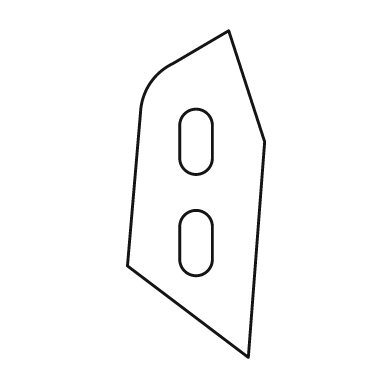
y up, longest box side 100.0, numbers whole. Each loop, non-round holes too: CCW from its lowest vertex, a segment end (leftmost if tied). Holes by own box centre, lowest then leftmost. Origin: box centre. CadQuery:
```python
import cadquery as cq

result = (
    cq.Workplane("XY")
    .moveTo(16.0, -50.0)
    .lineTo(21.0, 16.0)
    .lineTo(10.0, 50.0)
    .lineTo(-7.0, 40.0)
    .threePointArc((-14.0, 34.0), (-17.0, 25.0))
    .lineTo(-21.0, -22.0)
    .close()
    .moveTo(-5.0, -20.0)
    .threePointArc((0.0, -25.0), (5.0, -20.0))
    .lineTo(5.0, -10.0)
    .threePointArc((0.0, -5.0), (-5.0, -10.0))
    .close()
    .moveTo(-5.0, 11.0)
    .threePointArc((0.0, 6.0), (5.0, 11.0))
    .lineTo(5.0, 21.0)
    .threePointArc((0.0, 26.0), (-5.0, 21.0))
    .close()
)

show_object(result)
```